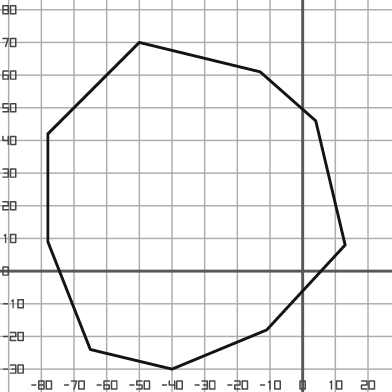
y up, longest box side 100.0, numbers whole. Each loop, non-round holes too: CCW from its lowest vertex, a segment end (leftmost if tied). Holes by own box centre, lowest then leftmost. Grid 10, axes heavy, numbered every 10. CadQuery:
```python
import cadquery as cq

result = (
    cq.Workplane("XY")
    .moveTo(-40.0, -30.0)
    .lineTo(-11.0, -18.0)
    .lineTo(13.0, 8.0)
    .lineTo(4.0, 46.0)
    .lineTo(-13.0, 61.0)
    .lineTo(-50.0, 70.0)
    .lineTo(-78.0, 42.0)
    .lineTo(-78.0, 9.0)
    .lineTo(-65.0, -24.0)
    .close()
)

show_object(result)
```